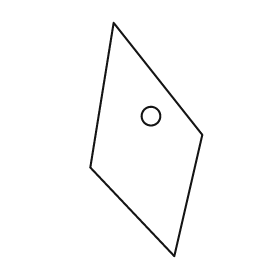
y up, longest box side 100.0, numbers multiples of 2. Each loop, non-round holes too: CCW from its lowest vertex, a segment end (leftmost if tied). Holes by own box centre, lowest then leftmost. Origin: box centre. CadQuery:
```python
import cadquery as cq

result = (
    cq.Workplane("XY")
    .moveTo(12.0, -50.0)
    .lineTo(24.0, 2.0)
    .lineTo(-14.0, 50.0)
    .lineTo(-24.0, -12.0)
    .close()
    .moveTo(2.0, 10.0)
    .circle(4.0)
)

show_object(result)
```